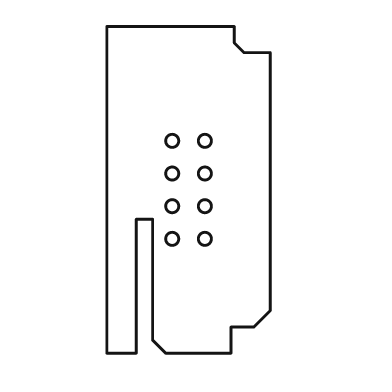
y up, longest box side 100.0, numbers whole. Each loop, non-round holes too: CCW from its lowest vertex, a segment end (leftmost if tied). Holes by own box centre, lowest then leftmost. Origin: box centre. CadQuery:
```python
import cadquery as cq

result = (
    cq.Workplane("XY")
    .moveTo(-25.0, -50.0)
    .lineTo(-16.0, -50.0)
    .lineTo(-16.0, -9.0)
    .lineTo(-11.0, -9.0)
    .lineTo(-11.0, -46.0)
    .lineTo(-7.0, -50.0)
    .lineTo(13.0, -50.0)
    .lineTo(13.0, -42.0)
    .lineTo(20.0, -42.0)
    .lineTo(25.0, -37.0)
    .lineTo(25.0, 42.0)
    .lineTo(17.0, 42.0)
    .lineTo(14.0, 45.0)
    .lineTo(14.0, 50.0)
    .lineTo(-25.0, 50.0)
    .close()
    .moveTo(-5.0, -15.0)
    .circle(2.0)
    .moveTo(5.0, -15.0)
    .circle(2.0)
    .moveTo(-5.0, -5.0)
    .circle(2.0)
    .moveTo(5.0, -5.0)
    .circle(2.0)
    .moveTo(-5.0, 5.0)
    .circle(2.0)
    .moveTo(5.0, 5.0)
    .circle(2.0)
    .moveTo(-5.0, 15.0)
    .circle(2.0)
    .moveTo(5.0, 15.0)
    .circle(2.0)
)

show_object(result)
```